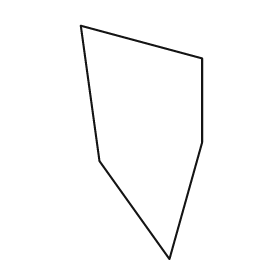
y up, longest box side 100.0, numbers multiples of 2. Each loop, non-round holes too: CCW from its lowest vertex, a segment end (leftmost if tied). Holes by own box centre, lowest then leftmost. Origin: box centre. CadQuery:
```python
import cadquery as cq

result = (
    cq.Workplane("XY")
    .moveTo(12.0, -50.0)
    .lineTo(26.0, 0.0)
    .lineTo(26.0, 36.0)
    .lineTo(-26.0, 50.0)
    .lineTo(-18.0, -8.0)
    .close()
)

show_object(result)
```